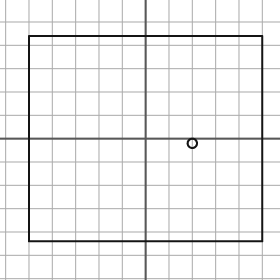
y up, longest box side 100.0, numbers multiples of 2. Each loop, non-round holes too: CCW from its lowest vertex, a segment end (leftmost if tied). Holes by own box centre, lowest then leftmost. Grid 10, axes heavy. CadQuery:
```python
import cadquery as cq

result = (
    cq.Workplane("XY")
    .moveTo(-50.0, -44.0)
    .lineTo(50.0, -44.0)
    .lineTo(50.0, 44.0)
    .lineTo(-50.0, 44.0)
    .close()
    .moveTo(20.0, -2.0)
    .circle(2.0)
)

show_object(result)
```